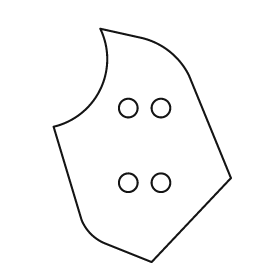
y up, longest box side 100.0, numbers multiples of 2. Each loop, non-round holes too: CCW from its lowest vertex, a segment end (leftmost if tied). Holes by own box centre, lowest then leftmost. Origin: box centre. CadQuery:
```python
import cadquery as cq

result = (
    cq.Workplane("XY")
    .moveTo(4.0, -50.0)
    .lineTo(38.0, -14.0)
    .lineTo(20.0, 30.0)
    .threePointArc((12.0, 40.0), (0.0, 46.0))
    .lineTo(-18.0, 50.0)
    .threePointArc((-18.0, 24.0), (-38.0, 8.0))
    .lineTo(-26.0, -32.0)
    .threePointArc((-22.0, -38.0), (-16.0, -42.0))
    .close()
    .moveTo(-6.0, -16.0)
    .circle(4.0)
    .moveTo(8.0, -16.0)
    .circle(4.0)
    .moveTo(-6.0, 16.0)
    .circle(4.0)
    .moveTo(8.0, 16.0)
    .circle(4.0)
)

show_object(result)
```